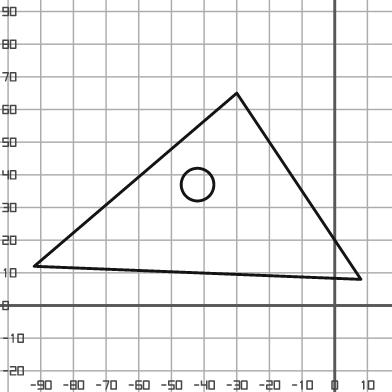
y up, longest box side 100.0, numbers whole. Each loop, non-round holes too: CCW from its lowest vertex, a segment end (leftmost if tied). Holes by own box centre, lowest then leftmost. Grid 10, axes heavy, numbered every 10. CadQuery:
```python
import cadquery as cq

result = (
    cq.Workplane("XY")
    .moveTo(8.0, 8.0)
    .lineTo(-30.0, 65.0)
    .lineTo(-92.0, 12.0)
    .close()
    .moveTo(-42.0, 37.0)
    .circle(5.0)
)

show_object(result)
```